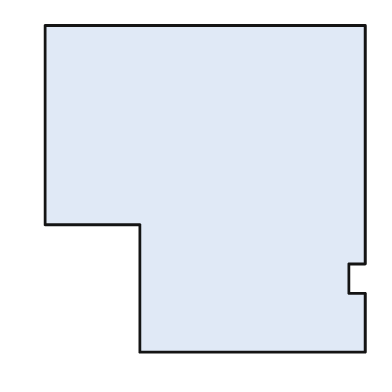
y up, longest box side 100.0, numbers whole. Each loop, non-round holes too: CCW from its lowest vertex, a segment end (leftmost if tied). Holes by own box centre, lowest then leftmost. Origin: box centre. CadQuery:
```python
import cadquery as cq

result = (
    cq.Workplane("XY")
    .moveTo(-20.0, -50.0)
    .lineTo(49.0, -50.0)
    .lineTo(49.0, -32.0)
    .lineTo(44.0, -32.0)
    .lineTo(44.0, -23.0)
    .lineTo(49.0, -23.0)
    .lineTo(49.0, 50.0)
    .lineTo(-49.0, 50.0)
    .lineTo(-49.0, -11.0)
    .lineTo(-20.0, -11.0)
    .close()
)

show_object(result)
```